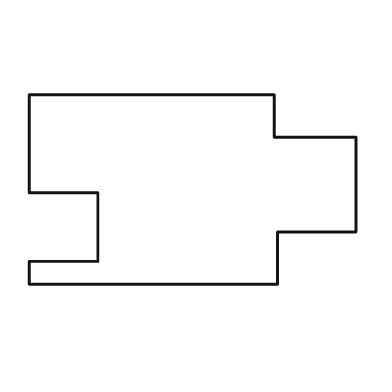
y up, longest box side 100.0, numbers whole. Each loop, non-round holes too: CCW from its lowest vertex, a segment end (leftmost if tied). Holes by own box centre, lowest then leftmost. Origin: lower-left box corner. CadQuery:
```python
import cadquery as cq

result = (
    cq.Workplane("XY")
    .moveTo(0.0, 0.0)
    .lineTo(76.0, 0.0)
    .lineTo(76.0, 16.0)
    .lineTo(100.0, 16.0)
    .lineTo(100.0, 45.0)
    .lineTo(75.0, 45.0)
    .lineTo(75.0, 58.0)
    .lineTo(0.0, 58.0)
    .lineTo(0.0, 28.0)
    .lineTo(21.0, 28.0)
    .lineTo(21.0, 7.0)
    .lineTo(0.0, 7.0)
    .close()
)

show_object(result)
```